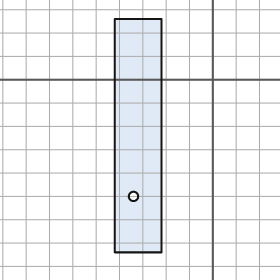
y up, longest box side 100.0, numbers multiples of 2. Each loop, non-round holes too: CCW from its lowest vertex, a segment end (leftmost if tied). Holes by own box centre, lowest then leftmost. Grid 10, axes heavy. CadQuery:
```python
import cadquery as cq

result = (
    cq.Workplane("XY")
    .moveTo(-42.0, -74.0)
    .lineTo(-22.0, -74.0)
    .lineTo(-22.0, 26.0)
    .lineTo(-42.0, 26.0)
    .close()
    .moveTo(-34.0, -50.0)
    .circle(2.0)
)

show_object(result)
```